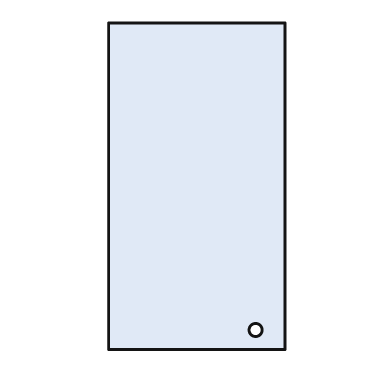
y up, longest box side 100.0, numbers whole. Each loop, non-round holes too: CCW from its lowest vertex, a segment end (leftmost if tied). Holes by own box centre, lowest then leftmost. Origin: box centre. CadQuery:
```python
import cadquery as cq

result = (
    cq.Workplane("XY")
    .moveTo(-27.0, -50.0)
    .lineTo(27.0, -50.0)
    .lineTo(27.0, 50.0)
    .lineTo(-27.0, 50.0)
    .close()
    .moveTo(18.0, -44.0)
    .circle(2.0)
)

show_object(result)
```